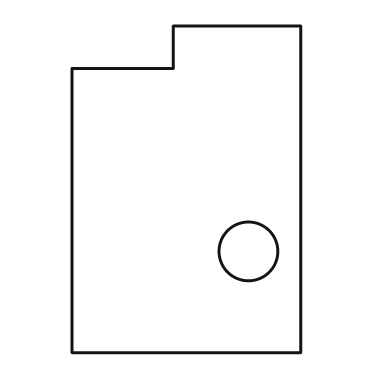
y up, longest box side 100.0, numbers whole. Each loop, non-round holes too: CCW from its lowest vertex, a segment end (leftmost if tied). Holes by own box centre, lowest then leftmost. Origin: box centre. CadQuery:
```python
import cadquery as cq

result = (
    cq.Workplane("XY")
    .moveTo(-35.0, -50.0)
    .lineTo(35.0, -50.0)
    .lineTo(35.0, 50.0)
    .lineTo(-4.0, 50.0)
    .lineTo(-4.0, 37.0)
    .lineTo(-35.0, 37.0)
    .close()
    .moveTo(19.0, -19.0)
    .circle(9.0)
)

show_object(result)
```